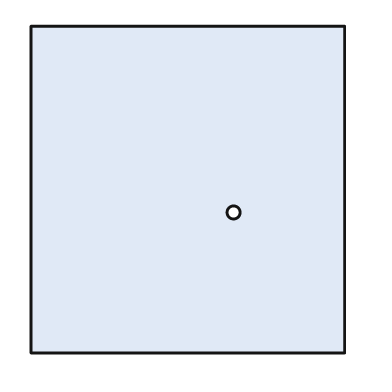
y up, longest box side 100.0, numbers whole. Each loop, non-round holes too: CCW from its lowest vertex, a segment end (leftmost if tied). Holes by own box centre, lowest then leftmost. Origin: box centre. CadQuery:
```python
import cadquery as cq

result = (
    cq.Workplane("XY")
    .moveTo(-48.0, -50.0)
    .lineTo(48.0, -50.0)
    .lineTo(48.0, 50.0)
    .lineTo(-48.0, 50.0)
    .close()
    .moveTo(14.0, -7.0)
    .circle(2.0)
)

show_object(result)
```